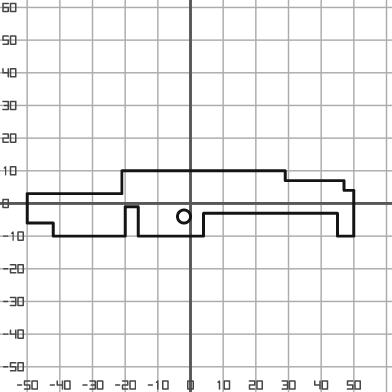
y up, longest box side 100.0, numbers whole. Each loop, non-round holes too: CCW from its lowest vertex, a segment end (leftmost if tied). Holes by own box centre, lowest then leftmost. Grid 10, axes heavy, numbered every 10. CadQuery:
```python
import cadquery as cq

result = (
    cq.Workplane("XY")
    .moveTo(-42.0, -10.0)
    .lineTo(-20.0, -10.0)
    .lineTo(-20.0, -1.0)
    .lineTo(-16.0, -1.0)
    .lineTo(-16.0, -10.0)
    .lineTo(4.0, -10.0)
    .lineTo(4.0, -3.0)
    .lineTo(45.0, -3.0)
    .lineTo(45.0, -10.0)
    .lineTo(50.0, -10.0)
    .lineTo(50.0, 4.0)
    .lineTo(47.0, 4.0)
    .lineTo(47.0, 7.0)
    .lineTo(29.0, 7.0)
    .lineTo(29.0, 10.0)
    .lineTo(-21.0, 10.0)
    .lineTo(-21.0, 3.0)
    .lineTo(-50.0, 3.0)
    .lineTo(-50.0, -6.0)
    .lineTo(-42.0, -6.0)
    .close()
    .moveTo(-2.0, -4.0)
    .circle(2.0)
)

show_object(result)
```